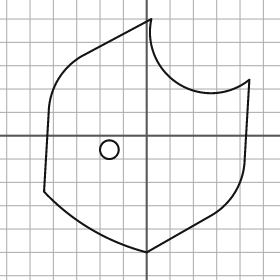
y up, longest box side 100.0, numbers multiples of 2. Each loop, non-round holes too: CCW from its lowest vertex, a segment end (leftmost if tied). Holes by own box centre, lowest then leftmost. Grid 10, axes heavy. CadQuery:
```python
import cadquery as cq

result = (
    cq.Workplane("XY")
    .moveTo(0.0, -50.0)
    .lineTo(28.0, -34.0)
    .threePointArc((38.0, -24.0), (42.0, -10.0))
    .lineTo(44.0, 24.0)
    .threePointArc((14.0, 22.0), (2.0, 50.0))
    .lineTo(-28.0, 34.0)
    .threePointArc((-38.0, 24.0), (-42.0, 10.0))
    .lineTo(-44.0, -24.0)
    .threePointArc((-24.0, -40.0), (0.0, -50.0))
    .close()
    .moveTo(-16.0, -6.0)
    .circle(4.0)
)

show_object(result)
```